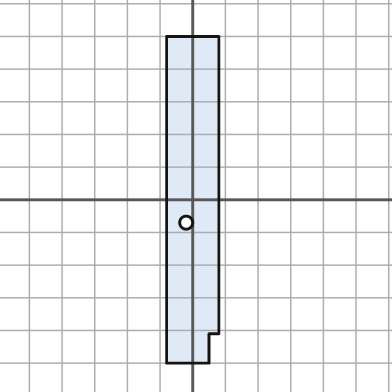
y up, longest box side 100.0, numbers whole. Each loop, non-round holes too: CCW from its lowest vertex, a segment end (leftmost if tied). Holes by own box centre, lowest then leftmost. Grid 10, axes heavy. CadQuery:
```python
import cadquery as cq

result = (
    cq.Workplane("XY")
    .moveTo(-8.0, -50.0)
    .lineTo(5.0, -50.0)
    .lineTo(5.0, -41.0)
    .lineTo(8.0, -41.0)
    .lineTo(8.0, 50.0)
    .lineTo(-8.0, 50.0)
    .close()
    .moveTo(-2.0, -7.0)
    .circle(2.0)
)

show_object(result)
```